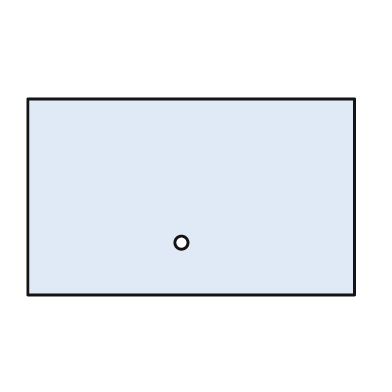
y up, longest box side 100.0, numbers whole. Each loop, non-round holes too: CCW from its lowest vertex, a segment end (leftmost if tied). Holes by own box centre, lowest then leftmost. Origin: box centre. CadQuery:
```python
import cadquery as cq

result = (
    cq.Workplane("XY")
    .moveTo(-50.0, -30.0)
    .lineTo(50.0, -30.0)
    .lineTo(50.0, 30.0)
    .lineTo(-50.0, 30.0)
    .close()
    .moveTo(-3.0, -14.0)
    .circle(2.0)
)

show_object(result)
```